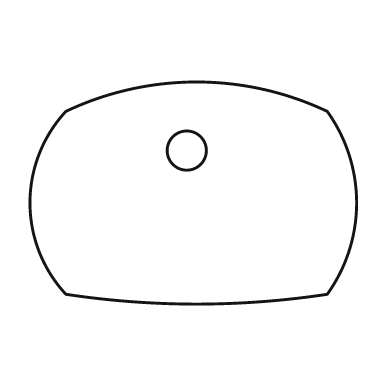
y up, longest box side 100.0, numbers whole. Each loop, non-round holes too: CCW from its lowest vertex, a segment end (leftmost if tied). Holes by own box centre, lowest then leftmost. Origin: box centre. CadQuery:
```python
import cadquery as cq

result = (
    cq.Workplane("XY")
    .moveTo(-39.0, -31.0)
    .threePointArc((1.0, -34.0), (41.0, -31.0))
    .threePointArc((50.0, -3.0), (41.0, 25.0))
    .threePointArc((1.0, 34.0), (-39.0, 25.0))
    .threePointArc((-50.0, -3.0), (-39.0, -31.0))
    .close()
    .moveTo(-2.0, 13.0)
    .circle(6.0)
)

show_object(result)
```